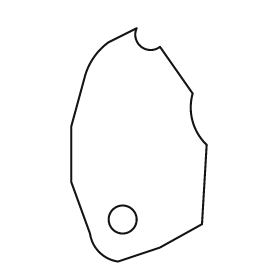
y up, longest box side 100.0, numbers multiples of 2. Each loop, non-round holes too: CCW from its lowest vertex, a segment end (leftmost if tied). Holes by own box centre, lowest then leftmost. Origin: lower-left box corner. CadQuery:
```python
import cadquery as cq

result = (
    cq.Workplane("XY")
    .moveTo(20.0, 0.0)
    .lineTo(38.0, 6.0)
    .lineTo(56.0, 16.0)
    .lineTo(58.0, 50.0)
    .threePointArc((52.0, 60.0), (52.0, 72.0))
    .lineTo(38.0, 92.0)
    .threePointArc((30.0, 92.0), (28.0, 100.0))
    .lineTo(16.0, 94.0)
    .threePointArc((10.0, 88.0), (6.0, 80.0))
    .lineTo(0.0, 58.0)
    .lineTo(0.0, 34.0)
    .lineTo(8.0, 12.0)
    .threePointArc((12.0, 4.0), (20.0, 0.0))
    .close()
    .moveTo(22.0, 18.0)
    .circle(6.0)
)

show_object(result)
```